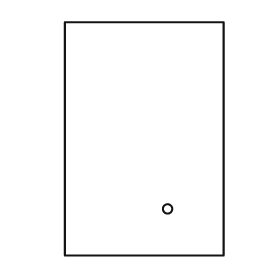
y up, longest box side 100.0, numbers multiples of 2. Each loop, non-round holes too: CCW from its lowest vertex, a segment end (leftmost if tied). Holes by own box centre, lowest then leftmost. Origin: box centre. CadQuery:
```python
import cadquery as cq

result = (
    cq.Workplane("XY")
    .moveTo(-34.0, -50.0)
    .lineTo(34.0, -50.0)
    .lineTo(34.0, 50.0)
    .lineTo(-34.0, 50.0)
    .close()
    .moveTo(10.0, -30.0)
    .circle(2.0)
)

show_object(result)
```